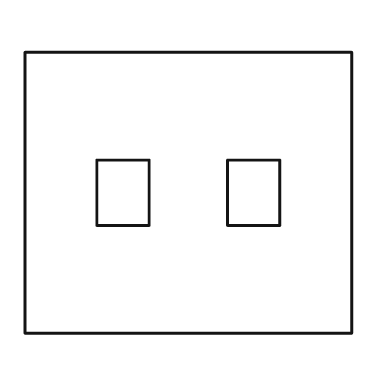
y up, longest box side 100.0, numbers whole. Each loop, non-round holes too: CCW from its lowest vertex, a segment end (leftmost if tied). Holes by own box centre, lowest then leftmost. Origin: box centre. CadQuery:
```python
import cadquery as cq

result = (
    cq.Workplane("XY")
    .moveTo(-50.0, -43.0)
    .lineTo(50.0, -43.0)
    .lineTo(50.0, 43.0)
    .lineTo(-50.0, 43.0)
    .close()
    .moveTo(-28.0, -10.0)
    .lineTo(-12.0, -10.0)
    .lineTo(-12.0, 10.0)
    .lineTo(-28.0, 10.0)
    .close()
    .moveTo(12.0, -10.0)
    .lineTo(28.0, -10.0)
    .lineTo(28.0, 10.0)
    .lineTo(12.0, 10.0)
    .close()
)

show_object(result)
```